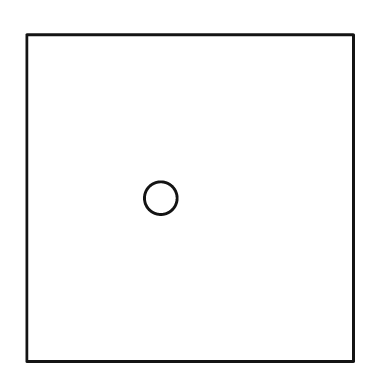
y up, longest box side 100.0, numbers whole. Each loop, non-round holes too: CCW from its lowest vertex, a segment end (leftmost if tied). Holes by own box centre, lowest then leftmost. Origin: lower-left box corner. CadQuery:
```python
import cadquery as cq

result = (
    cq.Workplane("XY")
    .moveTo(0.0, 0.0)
    .lineTo(100.0, 0.0)
    .lineTo(100.0, 100.0)
    .lineTo(0.0, 100.0)
    .close()
    .moveTo(41.0, 50.0)
    .circle(5.0)
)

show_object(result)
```